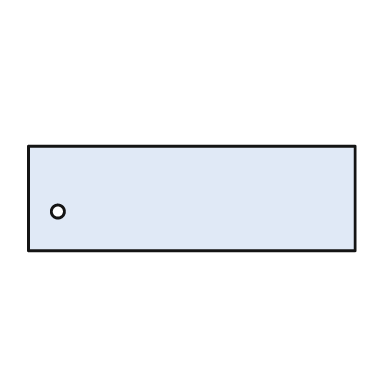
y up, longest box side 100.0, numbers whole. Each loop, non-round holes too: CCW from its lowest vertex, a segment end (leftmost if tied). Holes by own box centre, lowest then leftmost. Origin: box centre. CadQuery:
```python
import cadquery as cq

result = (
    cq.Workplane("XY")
    .moveTo(-50.0, -16.0)
    .lineTo(50.0, -16.0)
    .lineTo(50.0, 16.0)
    .lineTo(-50.0, 16.0)
    .close()
    .moveTo(-41.0, -4.0)
    .circle(2.0)
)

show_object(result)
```